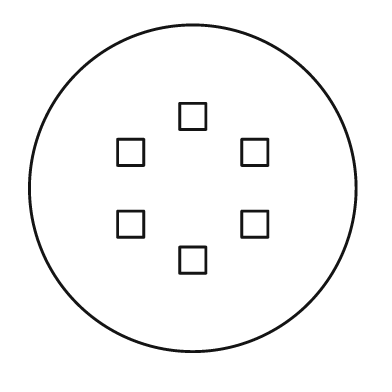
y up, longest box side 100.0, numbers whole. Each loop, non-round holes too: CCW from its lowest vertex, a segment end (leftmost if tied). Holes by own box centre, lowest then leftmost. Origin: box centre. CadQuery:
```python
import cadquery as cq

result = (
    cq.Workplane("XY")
    .moveTo(0.0, 0.0)
    .circle(50.0)
    .moveTo(-4.0, -26.0)
    .lineTo(4.0, -26.0)
    .lineTo(4.0, -18.0)
    .lineTo(-4.0, -18.0)
    .close()
    .moveTo(-23.0, -15.0)
    .lineTo(-15.0, -15.0)
    .lineTo(-15.0, -7.0)
    .lineTo(-23.0, -7.0)
    .close()
    .moveTo(15.0, -15.0)
    .lineTo(23.0, -15.0)
    .lineTo(23.0, -7.0)
    .lineTo(15.0, -7.0)
    .close()
    .moveTo(-23.0, 7.0)
    .lineTo(-15.0, 7.0)
    .lineTo(-15.0, 15.0)
    .lineTo(-23.0, 15.0)
    .close()
    .moveTo(15.0, 7.0)
    .lineTo(23.0, 7.0)
    .lineTo(23.0, 15.0)
    .lineTo(15.0, 15.0)
    .close()
    .moveTo(-4.0, 18.0)
    .lineTo(4.0, 18.0)
    .lineTo(4.0, 26.0)
    .lineTo(-4.0, 26.0)
    .close()
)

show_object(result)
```